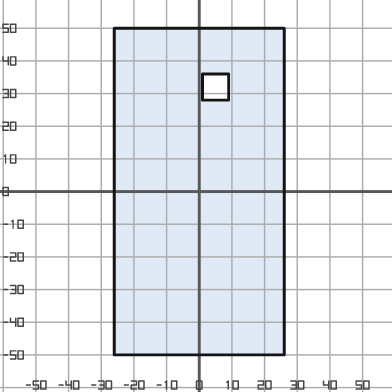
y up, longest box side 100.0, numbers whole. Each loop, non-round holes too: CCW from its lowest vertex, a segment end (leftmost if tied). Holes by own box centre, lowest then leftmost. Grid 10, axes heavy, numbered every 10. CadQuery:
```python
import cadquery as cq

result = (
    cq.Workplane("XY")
    .moveTo(-26.0, -50.0)
    .lineTo(26.0, -50.0)
    .lineTo(26.0, 50.0)
    .lineTo(-26.0, 50.0)
    .close()
    .moveTo(1.0, 28.0)
    .lineTo(9.0, 28.0)
    .lineTo(9.0, 36.0)
    .lineTo(1.0, 36.0)
    .close()
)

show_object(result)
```